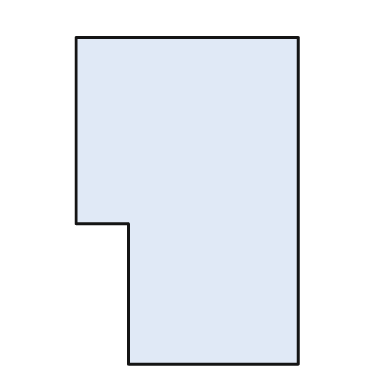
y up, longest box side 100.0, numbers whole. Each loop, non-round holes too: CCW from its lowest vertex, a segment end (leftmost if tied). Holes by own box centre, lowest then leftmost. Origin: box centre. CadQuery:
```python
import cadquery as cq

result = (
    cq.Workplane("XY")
    .moveTo(-18.0, -50.0)
    .lineTo(34.0, -50.0)
    .lineTo(34.0, 50.0)
    .lineTo(-34.0, 50.0)
    .lineTo(-34.0, -7.0)
    .lineTo(-18.0, -7.0)
    .close()
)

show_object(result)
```